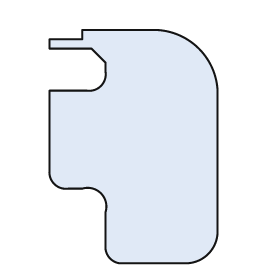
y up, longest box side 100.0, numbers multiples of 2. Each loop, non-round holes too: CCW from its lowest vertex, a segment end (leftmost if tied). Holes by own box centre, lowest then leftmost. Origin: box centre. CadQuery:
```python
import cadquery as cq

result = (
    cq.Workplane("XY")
    .moveTo(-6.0, -50.0)
    .lineTo(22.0, -50.0)
    .threePointArc((32.0, -46.0), (36.0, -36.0))
    .lineTo(36.0, 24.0)
    .threePointArc((28.0, 42.0), (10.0, 50.0))
    .lineTo(-22.0, 50.0)
    .lineTo(-22.0, 46.0)
    .lineTo(-36.0, 46.0)
    .lineTo(-36.0, 42.0)
    .lineTo(-18.0, 42.0)
    .lineTo(-12.0, 36.0)
    .lineTo(-12.0, 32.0)
    .threePointArc((-14.0, 26.0), (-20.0, 24.0))
    .lineTo(-36.0, 24.0)
    .lineTo(-36.0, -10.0)
    .threePointArc((-34.0, -16.0), (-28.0, -18.0))
    .lineTo(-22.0, -18.0)
    .threePointArc((-14.0, -20.0), (-12.0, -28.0))
    .lineTo(-12.0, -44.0)
    .threePointArc((-10.0, -48.0), (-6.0, -50.0))
    .close()
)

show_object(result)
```